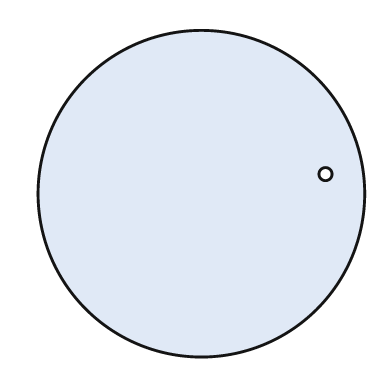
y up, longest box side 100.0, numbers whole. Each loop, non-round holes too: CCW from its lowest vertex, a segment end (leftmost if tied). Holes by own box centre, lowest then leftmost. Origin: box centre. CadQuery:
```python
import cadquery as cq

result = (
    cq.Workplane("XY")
    .moveTo(0.0, 0.0)
    .circle(50.0)
    .moveTo(38.0, 6.0)
    .circle(2.0)
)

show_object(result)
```